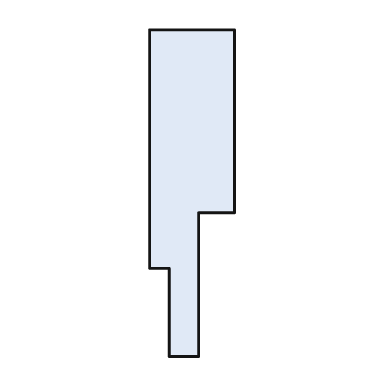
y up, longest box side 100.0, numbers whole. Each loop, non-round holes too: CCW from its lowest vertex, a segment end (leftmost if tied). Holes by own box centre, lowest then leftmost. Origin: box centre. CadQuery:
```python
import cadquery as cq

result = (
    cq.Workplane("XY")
    .moveTo(-7.0, -50.0)
    .lineTo(2.0, -50.0)
    .lineTo(2.0, -6.0)
    .lineTo(13.0, -6.0)
    .lineTo(13.0, 50.0)
    .lineTo(-13.0, 50.0)
    .lineTo(-13.0, -23.0)
    .lineTo(-7.0, -23.0)
    .close()
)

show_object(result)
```